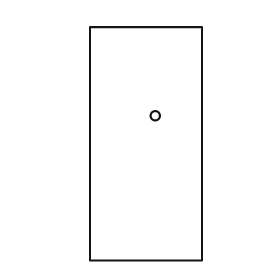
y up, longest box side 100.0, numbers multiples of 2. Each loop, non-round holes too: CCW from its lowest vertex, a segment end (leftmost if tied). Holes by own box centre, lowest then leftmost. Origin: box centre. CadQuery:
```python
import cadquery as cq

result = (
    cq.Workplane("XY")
    .moveTo(-24.0, -50.0)
    .lineTo(24.0, -50.0)
    .lineTo(24.0, 50.0)
    .lineTo(-24.0, 50.0)
    .close()
    .moveTo(4.0, 12.0)
    .circle(2.0)
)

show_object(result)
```